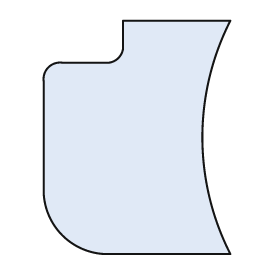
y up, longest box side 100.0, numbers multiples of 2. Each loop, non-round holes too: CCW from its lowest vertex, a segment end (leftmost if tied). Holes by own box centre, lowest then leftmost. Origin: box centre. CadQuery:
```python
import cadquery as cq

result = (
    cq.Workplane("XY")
    .moveTo(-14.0, -50.0)
    .lineTo(40.0, -50.0)
    .threePointArc((28.0, 0.0), (40.0, 50.0))
    .lineTo(-6.0, 50.0)
    .lineTo(-6.0, 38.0)
    .threePointArc((-8.0, 34.0), (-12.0, 32.0))
    .lineTo(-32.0, 32.0)
    .threePointArc((-38.0, 30.0), (-40.0, 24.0))
    .lineTo(-40.0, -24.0)
    .threePointArc((-32.0, -42.0), (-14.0, -50.0))
    .close()
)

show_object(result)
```